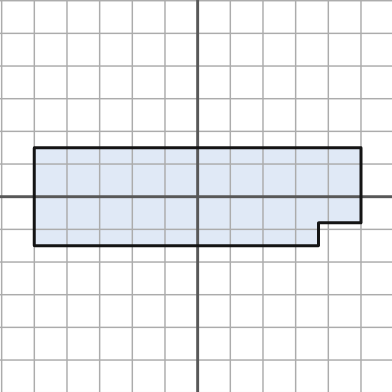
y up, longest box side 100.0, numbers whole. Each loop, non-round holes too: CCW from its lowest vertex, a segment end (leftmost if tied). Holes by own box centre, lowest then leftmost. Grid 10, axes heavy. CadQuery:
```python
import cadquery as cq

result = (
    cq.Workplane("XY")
    .moveTo(-50.0, -15.0)
    .lineTo(37.0, -15.0)
    .lineTo(37.0, -8.0)
    .lineTo(50.0, -8.0)
    .lineTo(50.0, 15.0)
    .lineTo(-50.0, 15.0)
    .close()
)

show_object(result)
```